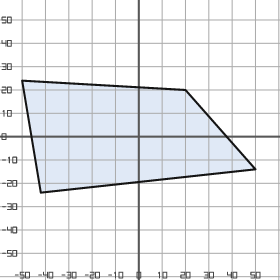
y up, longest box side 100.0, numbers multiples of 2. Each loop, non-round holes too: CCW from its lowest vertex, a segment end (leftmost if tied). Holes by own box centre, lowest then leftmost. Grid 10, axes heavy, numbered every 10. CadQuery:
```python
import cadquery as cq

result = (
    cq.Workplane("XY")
    .moveTo(-42.0, -24.0)
    .lineTo(50.0, -14.0)
    .lineTo(20.0, 20.0)
    .lineTo(-50.0, 24.0)
    .close()
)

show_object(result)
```